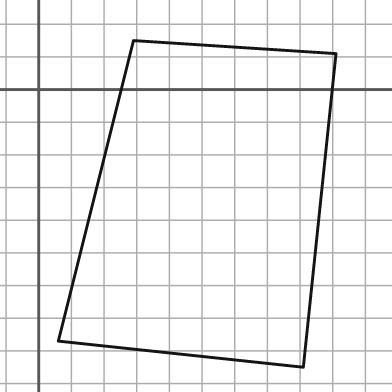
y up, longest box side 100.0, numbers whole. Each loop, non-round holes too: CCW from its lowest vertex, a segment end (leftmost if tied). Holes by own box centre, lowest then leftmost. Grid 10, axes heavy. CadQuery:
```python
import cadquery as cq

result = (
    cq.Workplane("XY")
    .moveTo(81.0, -85.0)
    .lineTo(91.0, 11.0)
    .lineTo(29.0, 15.0)
    .lineTo(6.0, -77.0)
    .close()
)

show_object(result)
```